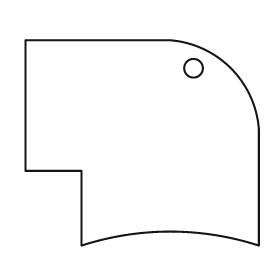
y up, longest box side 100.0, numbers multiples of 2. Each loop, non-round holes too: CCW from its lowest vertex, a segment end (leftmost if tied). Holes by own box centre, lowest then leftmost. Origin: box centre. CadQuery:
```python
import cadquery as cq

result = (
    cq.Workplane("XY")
    .moveTo(-26.0, -44.0)
    .threePointArc((12.0, -38.0), (50.0, -44.0))
    .lineTo(50.0, 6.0)
    .threePointArc((38.0, 32.0), (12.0, 44.0))
    .lineTo(-50.0, 44.0)
    .lineTo(-50.0, -12.0)
    .lineTo(-26.0, -12.0)
    .close()
    .moveTo(22.0, 32.0)
    .circle(4.0)
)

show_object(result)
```